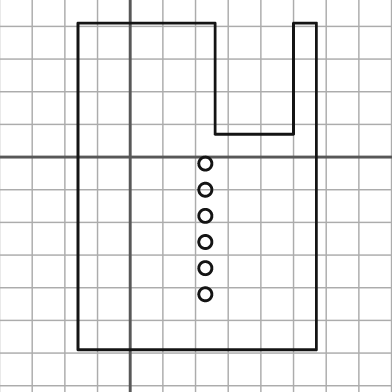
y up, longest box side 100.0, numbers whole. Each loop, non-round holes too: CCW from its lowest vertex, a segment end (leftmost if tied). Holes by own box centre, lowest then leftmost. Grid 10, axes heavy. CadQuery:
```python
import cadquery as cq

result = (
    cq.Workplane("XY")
    .moveTo(-16.0, -59.0)
    .lineTo(57.0, -59.0)
    .lineTo(57.0, 41.0)
    .lineTo(50.0, 41.0)
    .lineTo(50.0, 7.0)
    .lineTo(26.0, 7.0)
    .lineTo(26.0, 41.0)
    .lineTo(-16.0, 41.0)
    .close()
    .moveTo(23.0, -42.0)
    .circle(2.0)
    .moveTo(23.0, -34.0)
    .circle(2.0)
    .moveTo(23.0, -26.0)
    .circle(2.0)
    .moveTo(23.0, -18.0)
    .circle(2.0)
    .moveTo(23.0, -10.0)
    .circle(2.0)
    .moveTo(23.0, -2.0)
    .circle(2.0)
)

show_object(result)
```